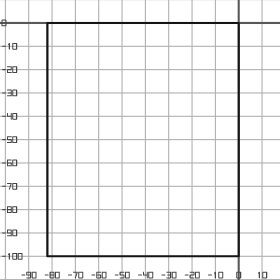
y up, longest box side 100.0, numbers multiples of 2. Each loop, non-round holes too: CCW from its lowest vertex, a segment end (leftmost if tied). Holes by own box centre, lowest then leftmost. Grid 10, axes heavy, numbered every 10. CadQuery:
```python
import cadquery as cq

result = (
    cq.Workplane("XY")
    .moveTo(-82.0, -100.0)
    .lineTo(0.0, -100.0)
    .lineTo(0.0, 0.0)
    .lineTo(-82.0, 0.0)
    .close()
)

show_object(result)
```